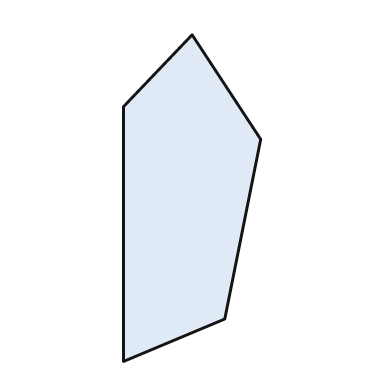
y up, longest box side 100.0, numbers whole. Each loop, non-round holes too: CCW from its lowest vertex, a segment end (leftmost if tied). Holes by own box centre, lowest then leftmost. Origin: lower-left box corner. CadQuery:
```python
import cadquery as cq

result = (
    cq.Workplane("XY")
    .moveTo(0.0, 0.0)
    .lineTo(31.0, 13.0)
    .lineTo(42.0, 68.0)
    .lineTo(21.0, 100.0)
    .lineTo(0.0, 78.0)
    .close()
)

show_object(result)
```